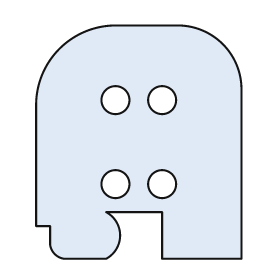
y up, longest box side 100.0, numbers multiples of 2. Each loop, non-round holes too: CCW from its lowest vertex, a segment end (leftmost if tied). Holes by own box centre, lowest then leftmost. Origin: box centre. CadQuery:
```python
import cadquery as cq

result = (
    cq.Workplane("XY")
    .moveTo(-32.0, -50.0)
    .lineTo(-14.0, -50.0)
    .threePointArc((-8.0, -40.0), (-14.0, -30.0))
    .lineTo(10.0, -30.0)
    .lineTo(10.0, -50.0)
    .lineTo(44.0, -50.0)
    .lineTo(44.0, 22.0)
    .threePointArc((36.0, 42.0), (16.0, 50.0))
    .lineTo(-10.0, 50.0)
    .threePointArc((-34.0, 40.0), (-44.0, 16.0))
    .lineTo(-44.0, -36.0)
    .lineTo(-38.0, -36.0)
    .lineTo(-38.0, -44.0)
    .threePointArc((-36.0, -48.0), (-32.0, -50.0))
    .close()
    .moveTo(-10.0, -18.0)
    .circle(6.0)
    .moveTo(10.0, -18.0)
    .circle(6.0)
    .moveTo(-10.0, 18.0)
    .circle(6.0)
    .moveTo(10.0, 18.0)
    .circle(6.0)
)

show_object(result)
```